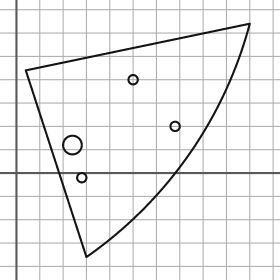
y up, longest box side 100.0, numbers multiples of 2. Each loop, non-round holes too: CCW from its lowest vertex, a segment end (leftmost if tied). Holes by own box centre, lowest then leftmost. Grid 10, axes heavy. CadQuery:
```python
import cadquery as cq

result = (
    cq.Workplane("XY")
    .moveTo(30.0, -36.0)
    .threePointArc((74.0, 8.0), (100.0, 64.0))
    .lineTo(4.0, 44.0)
    .close()
    .moveTo(28.0, -2.0)
    .circle(2.0)
    .moveTo(24.0, 12.0)
    .circle(4.0)
    .moveTo(68.0, 20.0)
    .circle(2.0)
    .moveTo(50.0, 40.0)
    .circle(2.0)
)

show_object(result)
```